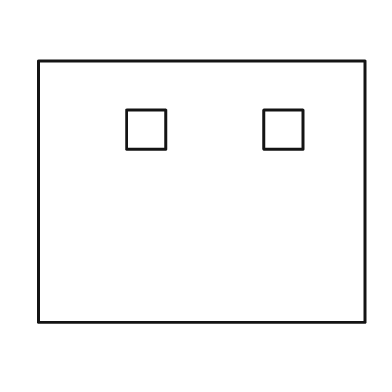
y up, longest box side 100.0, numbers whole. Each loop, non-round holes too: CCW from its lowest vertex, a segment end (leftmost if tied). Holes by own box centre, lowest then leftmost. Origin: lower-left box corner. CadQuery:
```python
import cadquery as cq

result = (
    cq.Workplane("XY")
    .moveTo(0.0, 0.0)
    .lineTo(100.0, 0.0)
    .lineTo(100.0, 80.0)
    .lineTo(0.0, 80.0)
    .close()
    .moveTo(27.0, 53.0)
    .lineTo(39.0, 53.0)
    .lineTo(39.0, 65.0)
    .lineTo(27.0, 65.0)
    .close()
    .moveTo(69.0, 53.0)
    .lineTo(81.0, 53.0)
    .lineTo(81.0, 65.0)
    .lineTo(69.0, 65.0)
    .close()
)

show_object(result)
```